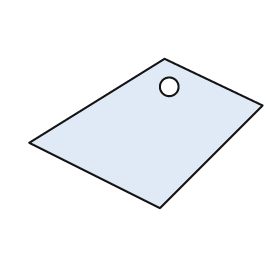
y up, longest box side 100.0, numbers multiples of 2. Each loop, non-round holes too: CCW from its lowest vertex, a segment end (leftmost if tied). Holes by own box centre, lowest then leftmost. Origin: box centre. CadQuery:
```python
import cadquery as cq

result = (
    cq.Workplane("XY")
    .moveTo(6.0, -32.0)
    .lineTo(50.0, 12.0)
    .lineTo(8.0, 32.0)
    .lineTo(-50.0, -4.0)
    .close()
    .moveTo(10.0, 20.0)
    .circle(4.0)
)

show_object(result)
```